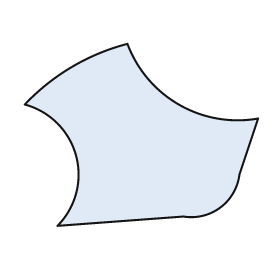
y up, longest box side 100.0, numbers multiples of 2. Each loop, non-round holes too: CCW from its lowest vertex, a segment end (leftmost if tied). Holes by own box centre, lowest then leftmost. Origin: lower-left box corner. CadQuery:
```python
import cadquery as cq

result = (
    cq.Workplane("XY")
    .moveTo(14.0, 0.0)
    .lineTo(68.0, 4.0)
    .threePointArc((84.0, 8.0), (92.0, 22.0))
    .lineTo(100.0, 46.0)
    .threePointArc((66.0, 52.0), (44.0, 78.0))
    .threePointArc((20.0, 68.0), (0.0, 52.0))
    .threePointArc((22.0, 30.0), (14.0, 0.0))
    .close()
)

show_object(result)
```